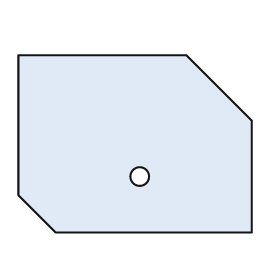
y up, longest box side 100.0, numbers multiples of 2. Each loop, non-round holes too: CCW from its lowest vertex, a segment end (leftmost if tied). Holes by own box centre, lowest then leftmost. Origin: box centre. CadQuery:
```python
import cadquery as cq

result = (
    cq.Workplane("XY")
    .moveTo(-34.0, -38.0)
    .lineTo(50.0, -38.0)
    .lineTo(50.0, 10.0)
    .lineTo(22.0, 38.0)
    .lineTo(-50.0, 38.0)
    .lineTo(-50.0, -22.0)
    .close()
    .moveTo(2.0, -14.0)
    .circle(4.0)
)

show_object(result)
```